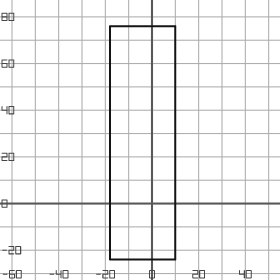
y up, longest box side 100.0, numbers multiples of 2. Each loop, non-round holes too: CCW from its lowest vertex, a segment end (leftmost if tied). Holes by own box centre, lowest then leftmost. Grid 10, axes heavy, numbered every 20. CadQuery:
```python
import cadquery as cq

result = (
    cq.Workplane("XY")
    .moveTo(-18.0, -24.0)
    .lineTo(10.0, -24.0)
    .lineTo(10.0, 76.0)
    .lineTo(-18.0, 76.0)
    .close()
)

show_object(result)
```